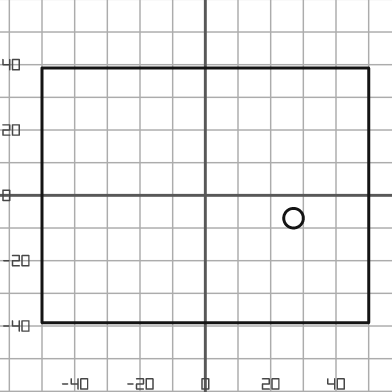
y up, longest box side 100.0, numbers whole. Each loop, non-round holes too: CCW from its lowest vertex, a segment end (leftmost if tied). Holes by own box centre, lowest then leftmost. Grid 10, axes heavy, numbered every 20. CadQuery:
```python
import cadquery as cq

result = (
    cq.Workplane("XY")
    .moveTo(-50.0, -39.0)
    .lineTo(50.0, -39.0)
    .lineTo(50.0, 39.0)
    .lineTo(-50.0, 39.0)
    .close()
    .moveTo(27.0, -7.0)
    .circle(3.0)
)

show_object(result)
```